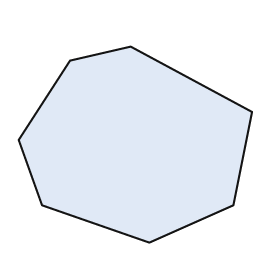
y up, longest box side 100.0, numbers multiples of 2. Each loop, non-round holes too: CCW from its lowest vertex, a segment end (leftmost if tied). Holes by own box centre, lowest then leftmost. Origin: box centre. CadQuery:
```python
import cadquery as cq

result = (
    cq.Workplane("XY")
    .moveTo(6.0, -42.0)
    .lineTo(42.0, -26.0)
    .lineTo(50.0, 14.0)
    .lineTo(-2.0, 42.0)
    .lineTo(-28.0, 36.0)
    .lineTo(-50.0, 2.0)
    .lineTo(-40.0, -26.0)
    .close()
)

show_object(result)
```